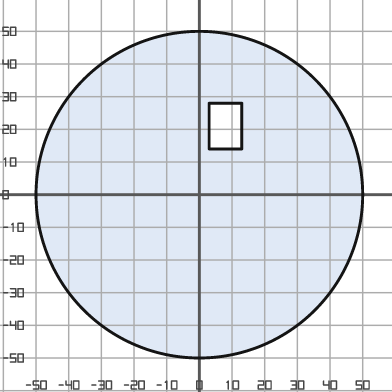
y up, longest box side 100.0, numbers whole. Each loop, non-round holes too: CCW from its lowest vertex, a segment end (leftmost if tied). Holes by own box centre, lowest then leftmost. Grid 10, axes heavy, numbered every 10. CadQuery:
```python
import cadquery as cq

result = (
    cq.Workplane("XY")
    .moveTo(0.0, 0.0)
    .circle(50.0)
    .moveTo(3.0, 14.0)
    .lineTo(13.0, 14.0)
    .lineTo(13.0, 28.0)
    .lineTo(3.0, 28.0)
    .close()
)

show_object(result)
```